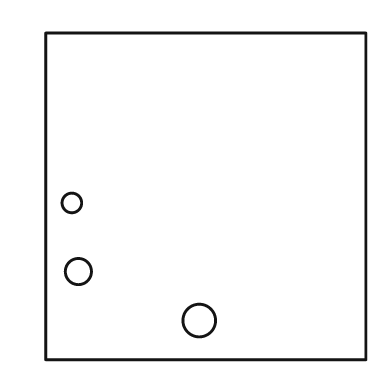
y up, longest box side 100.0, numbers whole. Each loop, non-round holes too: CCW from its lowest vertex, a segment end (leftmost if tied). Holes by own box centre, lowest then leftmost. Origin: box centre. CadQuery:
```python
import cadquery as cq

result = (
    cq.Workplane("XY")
    .moveTo(-49.0, -50.0)
    .lineTo(49.0, -50.0)
    .lineTo(49.0, 50.0)
    .lineTo(-49.0, 50.0)
    .close()
    .moveTo(-2.0, -38.0)
    .circle(5.0)
    .moveTo(-39.0, -23.0)
    .circle(4.0)
    .moveTo(-41.0, -2.0)
    .circle(3.0)
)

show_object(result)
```